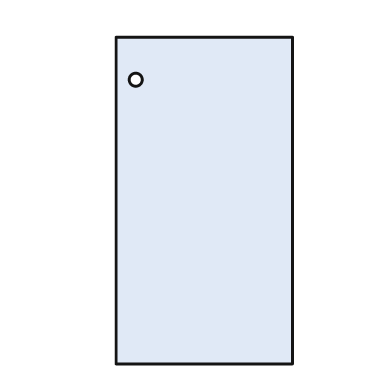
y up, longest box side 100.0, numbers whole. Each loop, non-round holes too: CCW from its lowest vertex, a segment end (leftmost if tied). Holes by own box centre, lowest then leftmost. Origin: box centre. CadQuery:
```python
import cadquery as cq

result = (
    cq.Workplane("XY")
    .moveTo(-27.0, -50.0)
    .lineTo(27.0, -50.0)
    .lineTo(27.0, 50.0)
    .lineTo(-27.0, 50.0)
    .close()
    .moveTo(-21.0, 37.0)
    .circle(2.0)
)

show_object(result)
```